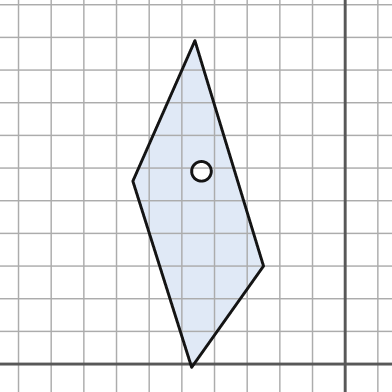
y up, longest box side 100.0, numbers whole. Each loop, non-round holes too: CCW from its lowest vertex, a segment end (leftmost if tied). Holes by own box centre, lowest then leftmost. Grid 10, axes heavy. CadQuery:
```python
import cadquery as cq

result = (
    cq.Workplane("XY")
    .moveTo(-47.0, -1.0)
    .lineTo(-25.0, 30.0)
    .lineTo(-46.0, 99.0)
    .lineTo(-65.0, 56.0)
    .close()
    .moveTo(-44.0, 59.0)
    .circle(3.0)
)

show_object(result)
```